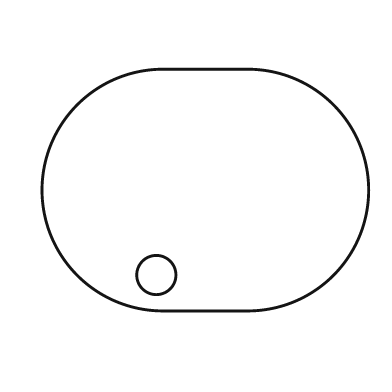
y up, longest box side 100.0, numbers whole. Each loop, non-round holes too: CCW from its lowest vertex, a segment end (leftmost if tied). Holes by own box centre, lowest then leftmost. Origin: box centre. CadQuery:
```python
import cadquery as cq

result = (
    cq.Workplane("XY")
    .moveTo(-13.0, -37.0)
    .lineTo(13.0, -37.0)
    .threePointArc((50.0, 0.0), (13.0, 37.0))
    .lineTo(-13.0, 37.0)
    .threePointArc((-50.0, 0.0), (-13.0, -37.0))
    .close()
    .moveTo(-15.0, -26.0)
    .circle(6.0)
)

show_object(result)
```